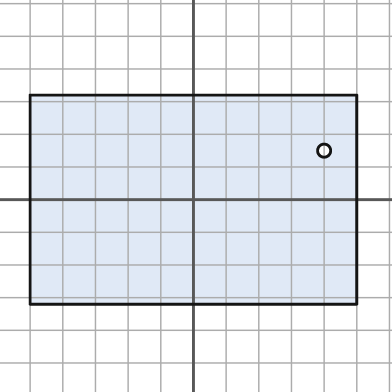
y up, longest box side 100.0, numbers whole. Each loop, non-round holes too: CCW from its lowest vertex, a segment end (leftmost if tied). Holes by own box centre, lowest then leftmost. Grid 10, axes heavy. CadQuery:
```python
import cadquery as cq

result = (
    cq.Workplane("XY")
    .moveTo(-50.0, -32.0)
    .lineTo(50.0, -32.0)
    .lineTo(50.0, 32.0)
    .lineTo(-50.0, 32.0)
    .close()
    .moveTo(40.0, 15.0)
    .circle(2.0)
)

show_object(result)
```